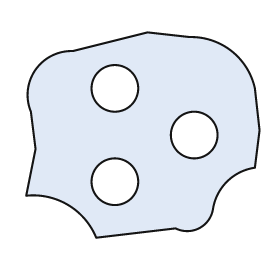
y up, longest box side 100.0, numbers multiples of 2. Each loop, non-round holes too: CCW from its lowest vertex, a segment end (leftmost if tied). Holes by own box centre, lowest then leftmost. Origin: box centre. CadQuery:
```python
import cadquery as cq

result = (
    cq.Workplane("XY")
    .moveTo(-20.0, -44.0)
    .lineTo(14.0, -40.0)
    .threePointArc((24.0, -40.0), (30.0, -32.0))
    .threePointArc((36.0, -20.0), (48.0, -14.0))
    .lineTo(50.0, 2.0)
    .lineTo(48.0, 20.0)
    .threePointArc((38.0, 36.0), (20.0, 42.0))
    .lineTo(2.0, 44.0)
    .lineTo(-30.0, 36.0)
    .threePointArc((-46.0, 28.0), (-48.0, 10.0))
    .lineTo(-46.0, -6.0)
    .lineTo(-50.0, -26.0)
    .threePointArc((-32.0, -30.0), (-20.0, -44.0))
    .close()
    .moveTo(-12.0, -20.0)
    .circle(10.0)
    .moveTo(22.0, 0.0)
    .circle(10.0)
    .moveTo(-12.0, 20.0)
    .circle(10.0)
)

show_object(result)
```